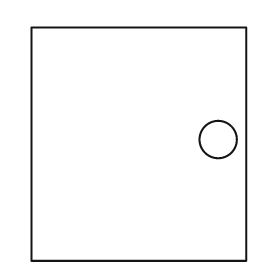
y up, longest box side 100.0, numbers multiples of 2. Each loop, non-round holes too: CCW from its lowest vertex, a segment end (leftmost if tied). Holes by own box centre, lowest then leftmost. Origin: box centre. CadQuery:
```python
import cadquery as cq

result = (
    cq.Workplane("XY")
    .moveTo(-46.0, -50.0)
    .lineTo(46.0, -50.0)
    .lineTo(46.0, 50.0)
    .lineTo(-46.0, 50.0)
    .close()
    .moveTo(34.0, 2.0)
    .circle(8.0)
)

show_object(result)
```